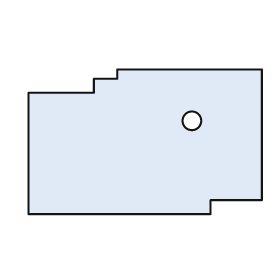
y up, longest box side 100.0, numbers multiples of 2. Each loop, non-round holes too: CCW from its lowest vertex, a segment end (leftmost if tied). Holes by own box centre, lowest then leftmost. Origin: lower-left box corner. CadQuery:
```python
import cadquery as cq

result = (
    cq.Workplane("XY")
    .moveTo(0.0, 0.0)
    .lineTo(78.0, 0.0)
    .lineTo(78.0, 6.0)
    .lineTo(100.0, 6.0)
    .lineTo(100.0, 62.0)
    .lineTo(38.0, 62.0)
    .lineTo(38.0, 58.0)
    .lineTo(28.0, 58.0)
    .lineTo(28.0, 52.0)
    .lineTo(0.0, 52.0)
    .close()
    .moveTo(70.0, 40.0)
    .circle(4.0)
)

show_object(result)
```